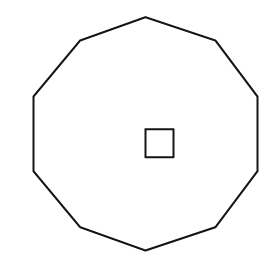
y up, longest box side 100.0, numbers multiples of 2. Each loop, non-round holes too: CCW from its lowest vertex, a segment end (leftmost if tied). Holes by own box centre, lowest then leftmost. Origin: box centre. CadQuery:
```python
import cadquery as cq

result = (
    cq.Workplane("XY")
    .moveTo(0.0, -50.0)
    .lineTo(30.0, -40.0)
    .lineTo(48.0, -16.0)
    .lineTo(48.0, 16.0)
    .lineTo(30.0, 40.0)
    .lineTo(0.0, 50.0)
    .lineTo(-28.0, 40.0)
    .lineTo(-48.0, 16.0)
    .lineTo(-48.0, -16.0)
    .lineTo(-28.0, -40.0)
    .close()
    .moveTo(0.0, -10.0)
    .lineTo(12.0, -10.0)
    .lineTo(12.0, 2.0)
    .lineTo(0.0, 2.0)
    .close()
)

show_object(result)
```